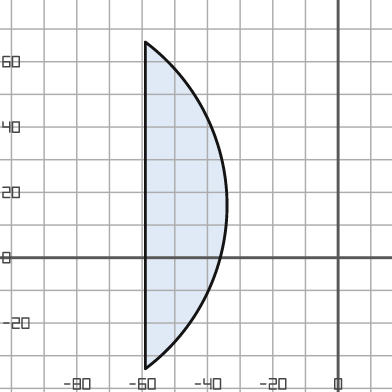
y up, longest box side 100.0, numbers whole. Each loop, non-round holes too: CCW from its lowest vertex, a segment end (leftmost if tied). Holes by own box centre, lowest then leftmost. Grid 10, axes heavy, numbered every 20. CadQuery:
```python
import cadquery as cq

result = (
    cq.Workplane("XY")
    .moveTo(-59.0, -34.0)
    .threePointArc((-34.0, 16.0), (-59.0, 66.0))
    .close()
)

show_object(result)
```